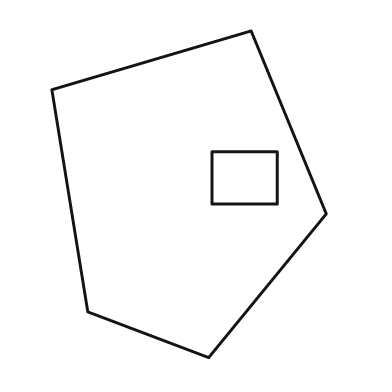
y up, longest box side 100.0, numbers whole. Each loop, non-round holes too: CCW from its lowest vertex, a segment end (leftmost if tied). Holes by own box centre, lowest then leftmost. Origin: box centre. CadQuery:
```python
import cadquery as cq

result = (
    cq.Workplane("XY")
    .moveTo(6.0, -50.0)
    .lineTo(42.0, -6.0)
    .lineTo(19.0, 50.0)
    .lineTo(-42.0, 32.0)
    .lineTo(-31.0, -36.0)
    .close()
    .moveTo(7.0, -3.0)
    .lineTo(27.0, -3.0)
    .lineTo(27.0, 13.0)
    .lineTo(7.0, 13.0)
    .close()
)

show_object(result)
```